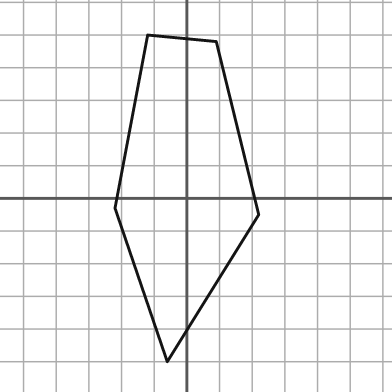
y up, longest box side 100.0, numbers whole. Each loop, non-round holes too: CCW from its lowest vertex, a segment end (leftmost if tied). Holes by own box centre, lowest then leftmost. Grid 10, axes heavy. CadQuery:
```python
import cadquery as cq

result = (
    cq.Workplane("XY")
    .moveTo(-6.0, -50.0)
    .lineTo(22.0, -5.0)
    .lineTo(9.0, 48.0)
    .lineTo(-12.0, 50.0)
    .lineTo(-22.0, -3.0)
    .close()
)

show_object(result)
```